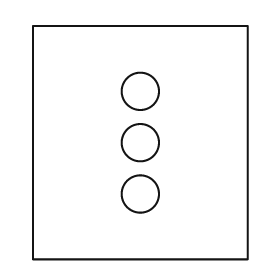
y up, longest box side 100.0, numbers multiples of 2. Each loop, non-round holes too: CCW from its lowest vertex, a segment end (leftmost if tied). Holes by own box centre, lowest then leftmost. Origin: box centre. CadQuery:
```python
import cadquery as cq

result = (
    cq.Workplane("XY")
    .moveTo(-46.0, -50.0)
    .lineTo(46.0, -50.0)
    .lineTo(46.0, 50.0)
    .lineTo(-46.0, 50.0)
    .close()
    .moveTo(0.0, -22.0)
    .circle(8.0)
    .moveTo(0.0, 0.0)
    .circle(8.0)
    .moveTo(0.0, 22.0)
    .circle(8.0)
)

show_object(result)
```